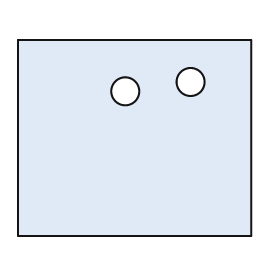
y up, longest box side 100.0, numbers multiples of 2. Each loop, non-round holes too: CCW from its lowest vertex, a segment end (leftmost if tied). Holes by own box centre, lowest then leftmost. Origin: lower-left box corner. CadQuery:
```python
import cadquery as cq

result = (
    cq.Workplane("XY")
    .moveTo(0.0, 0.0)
    .lineTo(100.0, 0.0)
    .lineTo(100.0, 84.0)
    .lineTo(0.0, 84.0)
    .close()
    .moveTo(46.0, 62.0)
    .circle(6.0)
    .moveTo(74.0, 66.0)
    .circle(6.0)
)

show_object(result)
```